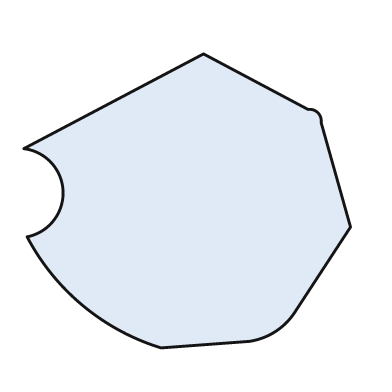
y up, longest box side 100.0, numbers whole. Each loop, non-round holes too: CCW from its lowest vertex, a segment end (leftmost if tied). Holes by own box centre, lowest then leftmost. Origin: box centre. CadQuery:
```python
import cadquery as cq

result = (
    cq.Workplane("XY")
    .moveTo(-8.0, -45.0)
    .lineTo(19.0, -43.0)
    .threePointArc((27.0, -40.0), (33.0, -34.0))
    .lineTo(50.0, -8.0)
    .lineTo(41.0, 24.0)
    .threePointArc((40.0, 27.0), (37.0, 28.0))
    .lineTo(5.0, 45.0)
    .lineTo(-50.0, 16.0)
    .threePointArc((-38.0, 3.0), (-49.0, -11.0))
    .threePointArc((-32.0, -32.0), (-8.0, -45.0))
    .close()
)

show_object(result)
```